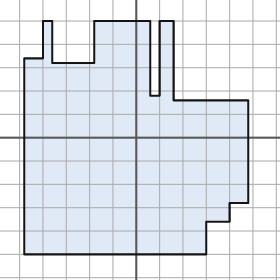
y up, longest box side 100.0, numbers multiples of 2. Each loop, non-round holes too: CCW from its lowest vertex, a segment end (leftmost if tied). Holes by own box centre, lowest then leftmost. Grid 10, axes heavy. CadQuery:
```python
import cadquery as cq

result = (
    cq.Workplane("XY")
    .moveTo(-48.0, -50.0)
    .lineTo(30.0, -50.0)
    .lineTo(30.0, -36.0)
    .lineTo(40.0, -36.0)
    .lineTo(40.0, -28.0)
    .lineTo(48.0, -28.0)
    .lineTo(48.0, 16.0)
    .lineTo(16.0, 16.0)
    .lineTo(16.0, 50.0)
    .lineTo(10.0, 50.0)
    .lineTo(10.0, 18.0)
    .lineTo(6.0, 18.0)
    .lineTo(6.0, 50.0)
    .lineTo(-18.0, 50.0)
    .lineTo(-18.0, 32.0)
    .lineTo(-36.0, 32.0)
    .lineTo(-36.0, 50.0)
    .lineTo(-40.0, 50.0)
    .lineTo(-40.0, 34.0)
    .lineTo(-48.0, 34.0)
    .close()
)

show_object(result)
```